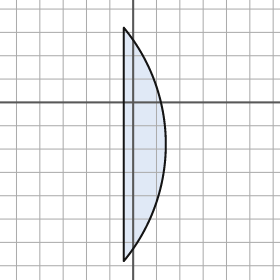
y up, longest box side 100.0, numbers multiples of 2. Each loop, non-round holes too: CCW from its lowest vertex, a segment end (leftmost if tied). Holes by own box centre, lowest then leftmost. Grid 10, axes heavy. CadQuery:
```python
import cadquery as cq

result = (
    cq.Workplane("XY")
    .moveTo(-4.0, -68.0)
    .threePointArc((14.0, -18.0), (-4.0, 32.0))
    .close()
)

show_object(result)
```